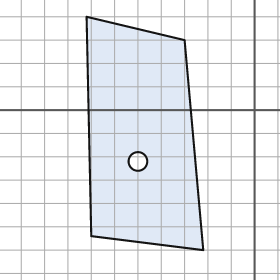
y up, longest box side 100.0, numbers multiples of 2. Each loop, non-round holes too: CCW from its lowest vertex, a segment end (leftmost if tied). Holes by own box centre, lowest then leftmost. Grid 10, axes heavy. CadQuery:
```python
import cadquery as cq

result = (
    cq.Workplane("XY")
    .moveTo(-22.0, -60.0)
    .lineTo(-30.0, 30.0)
    .lineTo(-72.0, 40.0)
    .lineTo(-70.0, -54.0)
    .close()
    .moveTo(-50.0, -22.0)
    .circle(4.0)
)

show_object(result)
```